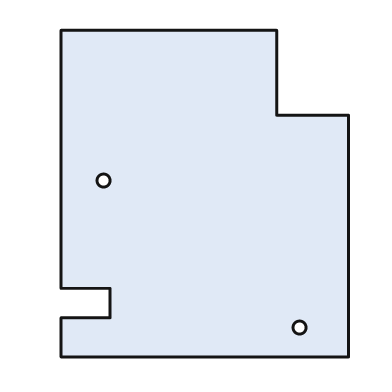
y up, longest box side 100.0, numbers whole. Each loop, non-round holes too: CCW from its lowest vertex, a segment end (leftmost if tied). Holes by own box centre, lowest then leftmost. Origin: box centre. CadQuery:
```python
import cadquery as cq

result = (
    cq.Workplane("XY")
    .moveTo(-44.0, -50.0)
    .lineTo(44.0, -50.0)
    .lineTo(44.0, 24.0)
    .lineTo(22.0, 24.0)
    .lineTo(22.0, 50.0)
    .lineTo(-44.0, 50.0)
    .lineTo(-44.0, -29.0)
    .lineTo(-29.0, -29.0)
    .lineTo(-29.0, -38.0)
    .lineTo(-44.0, -38.0)
    .close()
    .moveTo(29.0, -41.0)
    .circle(2.0)
    .moveTo(-31.0, 4.0)
    .circle(2.0)
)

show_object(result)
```